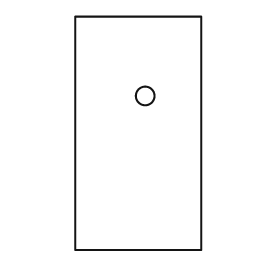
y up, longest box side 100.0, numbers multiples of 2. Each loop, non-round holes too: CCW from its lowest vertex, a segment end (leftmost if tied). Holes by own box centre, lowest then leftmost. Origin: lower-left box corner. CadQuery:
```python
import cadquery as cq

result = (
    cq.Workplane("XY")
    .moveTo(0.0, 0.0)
    .lineTo(54.0, 0.0)
    .lineTo(54.0, 100.0)
    .lineTo(0.0, 100.0)
    .close()
    .moveTo(30.0, 66.0)
    .circle(4.0)
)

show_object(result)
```